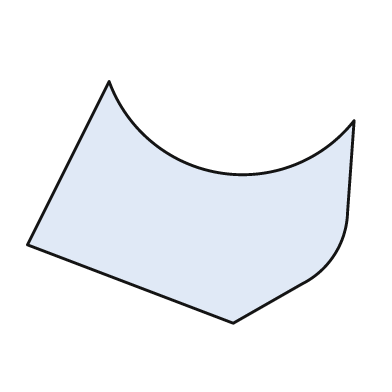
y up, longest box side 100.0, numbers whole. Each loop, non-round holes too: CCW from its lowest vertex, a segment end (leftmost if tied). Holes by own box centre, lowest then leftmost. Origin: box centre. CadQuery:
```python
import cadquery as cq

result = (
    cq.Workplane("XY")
    .moveTo(13.0, -37.0)
    .lineTo(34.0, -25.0)
    .threePointArc((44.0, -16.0), (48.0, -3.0))
    .lineTo(50.0, 25.0)
    .threePointArc((9.0, 9.0), (-25.0, 37.0))
    .lineTo(-50.0, -13.0)
    .close()
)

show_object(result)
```